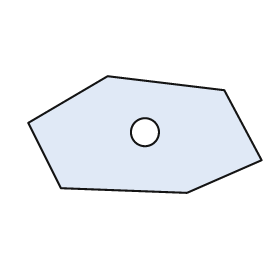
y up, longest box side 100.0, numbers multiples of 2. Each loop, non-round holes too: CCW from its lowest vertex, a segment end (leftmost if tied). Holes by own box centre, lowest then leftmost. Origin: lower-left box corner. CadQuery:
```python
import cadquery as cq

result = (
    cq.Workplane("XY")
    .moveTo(68.0, 0.0)
    .lineTo(100.0, 14.0)
    .lineTo(84.0, 44.0)
    .lineTo(34.0, 50.0)
    .lineTo(0.0, 30.0)
    .lineTo(14.0, 2.0)
    .close()
    .moveTo(50.0, 26.0)
    .circle(6.0)
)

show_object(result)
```